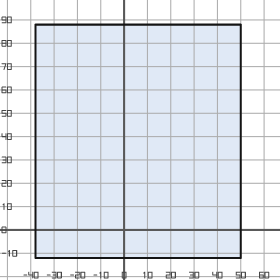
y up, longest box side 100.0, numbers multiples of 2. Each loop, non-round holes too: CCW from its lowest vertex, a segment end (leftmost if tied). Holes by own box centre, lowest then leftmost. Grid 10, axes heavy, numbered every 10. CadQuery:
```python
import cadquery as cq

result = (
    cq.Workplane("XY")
    .moveTo(-38.0, -12.0)
    .lineTo(50.0, -12.0)
    .lineTo(50.0, 88.0)
    .lineTo(-38.0, 88.0)
    .close()
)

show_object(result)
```